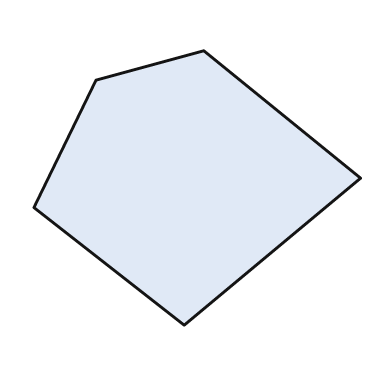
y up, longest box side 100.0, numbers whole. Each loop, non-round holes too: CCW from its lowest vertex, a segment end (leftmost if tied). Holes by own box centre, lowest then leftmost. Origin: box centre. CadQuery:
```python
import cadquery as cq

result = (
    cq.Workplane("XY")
    .moveTo(-4.0, -42.0)
    .lineTo(50.0, 3.0)
    .lineTo(2.0, 42.0)
    .lineTo(-31.0, 33.0)
    .lineTo(-50.0, -6.0)
    .close()
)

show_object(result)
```